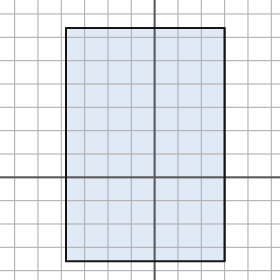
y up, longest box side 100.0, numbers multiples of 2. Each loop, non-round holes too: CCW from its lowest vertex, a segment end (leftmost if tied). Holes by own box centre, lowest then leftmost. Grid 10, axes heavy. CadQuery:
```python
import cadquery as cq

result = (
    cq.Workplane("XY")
    .moveTo(-38.0, -36.0)
    .lineTo(30.0, -36.0)
    .lineTo(30.0, 64.0)
    .lineTo(-38.0, 64.0)
    .close()
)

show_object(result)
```